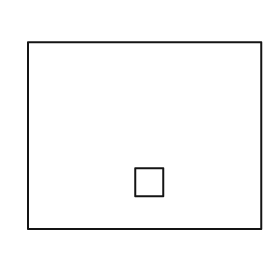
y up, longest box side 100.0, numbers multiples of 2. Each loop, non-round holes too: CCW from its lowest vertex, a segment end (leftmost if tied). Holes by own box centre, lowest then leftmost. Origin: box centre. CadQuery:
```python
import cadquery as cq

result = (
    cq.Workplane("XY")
    .moveTo(-50.0, -40.0)
    .lineTo(50.0, -40.0)
    .lineTo(50.0, 40.0)
    .lineTo(-50.0, 40.0)
    .close()
    .moveTo(-4.0, -26.0)
    .lineTo(8.0, -26.0)
    .lineTo(8.0, -14.0)
    .lineTo(-4.0, -14.0)
    .close()
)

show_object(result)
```